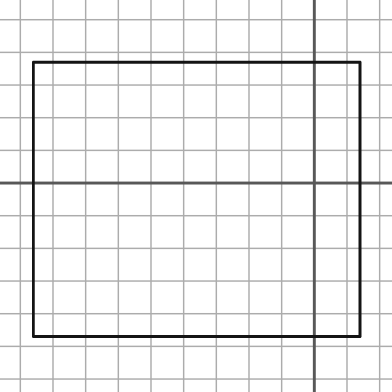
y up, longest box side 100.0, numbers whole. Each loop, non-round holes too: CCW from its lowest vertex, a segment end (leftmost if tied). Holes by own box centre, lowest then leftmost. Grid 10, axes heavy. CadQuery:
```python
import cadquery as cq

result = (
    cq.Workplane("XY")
    .moveTo(-86.0, -47.0)
    .lineTo(14.0, -47.0)
    .lineTo(14.0, 37.0)
    .lineTo(-86.0, 37.0)
    .close()
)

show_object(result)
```